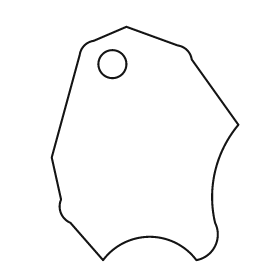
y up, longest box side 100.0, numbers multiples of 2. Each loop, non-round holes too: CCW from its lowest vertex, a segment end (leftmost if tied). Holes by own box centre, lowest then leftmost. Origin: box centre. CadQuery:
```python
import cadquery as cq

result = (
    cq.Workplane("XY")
    .moveTo(-18.0, -50.0)
    .threePointArc((2.0, -40.0), (22.0, -50.0))
    .threePointArc((30.0, -44.0), (30.0, -34.0))
    .threePointArc((30.0, -12.0), (40.0, 8.0))
    .lineTo(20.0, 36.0)
    .threePointArc((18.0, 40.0), (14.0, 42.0))
    .lineTo(-8.0, 50.0)
    .lineTo(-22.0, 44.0)
    .threePointArc((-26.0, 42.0), (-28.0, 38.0))
    .lineTo(-40.0, -6.0)
    .lineTo(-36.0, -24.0)
    .threePointArc((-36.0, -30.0), (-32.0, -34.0))
    .close()
    .moveTo(-14.0, 34.0)
    .circle(6.0)
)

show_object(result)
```